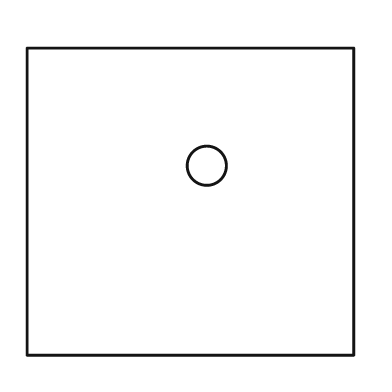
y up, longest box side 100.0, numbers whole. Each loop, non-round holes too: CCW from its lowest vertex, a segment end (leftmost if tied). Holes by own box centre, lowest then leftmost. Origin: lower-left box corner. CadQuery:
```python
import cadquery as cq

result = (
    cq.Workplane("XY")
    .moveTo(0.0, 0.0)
    .lineTo(100.0, 0.0)
    .lineTo(100.0, 94.0)
    .lineTo(0.0, 94.0)
    .close()
    .moveTo(55.0, 58.0)
    .circle(6.0)
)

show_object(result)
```